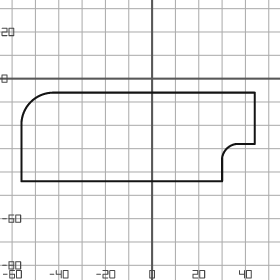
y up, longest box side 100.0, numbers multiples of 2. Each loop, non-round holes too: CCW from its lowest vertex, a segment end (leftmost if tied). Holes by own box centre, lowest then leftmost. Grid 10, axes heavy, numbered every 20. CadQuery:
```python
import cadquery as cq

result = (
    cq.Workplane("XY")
    .moveTo(-56.0, -44.0)
    .lineTo(30.0, -44.0)
    .lineTo(30.0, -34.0)
    .threePointArc((32.0, -30.0), (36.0, -28.0))
    .lineTo(44.0, -28.0)
    .lineTo(44.0, -6.0)
    .lineTo(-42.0, -6.0)
    .threePointArc((-52.0, -10.0), (-56.0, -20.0))
    .close()
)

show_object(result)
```